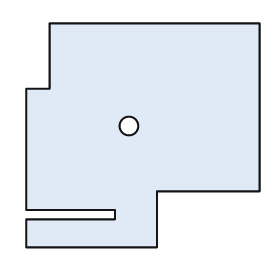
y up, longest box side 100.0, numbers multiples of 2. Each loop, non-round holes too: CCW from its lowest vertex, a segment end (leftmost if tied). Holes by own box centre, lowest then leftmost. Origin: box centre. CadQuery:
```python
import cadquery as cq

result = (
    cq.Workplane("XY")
    .moveTo(-50.0, -48.0)
    .lineTo(6.0, -48.0)
    .lineTo(6.0, -24.0)
    .lineTo(50.0, -24.0)
    .lineTo(50.0, 48.0)
    .lineTo(-40.0, 48.0)
    .lineTo(-40.0, 20.0)
    .lineTo(-50.0, 20.0)
    .lineTo(-50.0, -32.0)
    .lineTo(-12.0, -32.0)
    .lineTo(-12.0, -36.0)
    .lineTo(-50.0, -36.0)
    .close()
    .moveTo(-6.0, 4.0)
    .circle(4.0)
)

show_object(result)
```